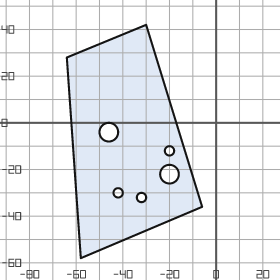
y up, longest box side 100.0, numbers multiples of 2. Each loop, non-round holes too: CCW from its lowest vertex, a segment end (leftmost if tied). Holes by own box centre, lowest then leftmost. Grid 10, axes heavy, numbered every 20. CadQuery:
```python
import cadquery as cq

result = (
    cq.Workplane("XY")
    .moveTo(-58.0, -58.0)
    .lineTo(-6.0, -36.0)
    .lineTo(-30.0, 42.0)
    .lineTo(-64.0, 28.0)
    .close()
    .moveTo(-32.0, -32.0)
    .circle(2.0)
    .moveTo(-42.0, -30.0)
    .circle(2.0)
    .moveTo(-20.0, -22.0)
    .circle(4.0)
    .moveTo(-20.0, -12.0)
    .circle(2.0)
    .moveTo(-46.0, -4.0)
    .circle(4.0)
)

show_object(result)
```